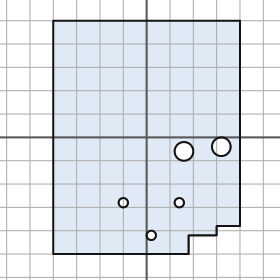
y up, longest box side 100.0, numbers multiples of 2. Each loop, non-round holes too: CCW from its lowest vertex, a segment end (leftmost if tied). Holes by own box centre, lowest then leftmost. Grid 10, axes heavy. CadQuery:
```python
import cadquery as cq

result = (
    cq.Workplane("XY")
    .moveTo(-40.0, -50.0)
    .lineTo(18.0, -50.0)
    .lineTo(18.0, -42.0)
    .lineTo(30.0, -42.0)
    .lineTo(30.0, -38.0)
    .lineTo(40.0, -38.0)
    .lineTo(40.0, 50.0)
    .lineTo(-40.0, 50.0)
    .close()
    .moveTo(2.0, -42.0)
    .circle(2.0)
    .moveTo(-10.0, -28.0)
    .circle(2.0)
    .moveTo(14.0, -28.0)
    .circle(2.0)
    .moveTo(16.0, -6.0)
    .circle(4.0)
    .moveTo(32.0, -4.0)
    .circle(4.0)
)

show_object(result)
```